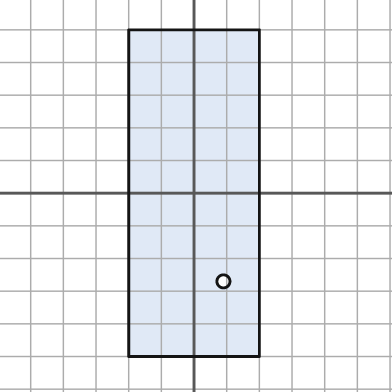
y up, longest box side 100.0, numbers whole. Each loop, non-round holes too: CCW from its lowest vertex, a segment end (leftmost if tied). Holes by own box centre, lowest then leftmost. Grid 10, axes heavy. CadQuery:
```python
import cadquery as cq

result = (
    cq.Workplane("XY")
    .moveTo(-20.0, -50.0)
    .lineTo(20.0, -50.0)
    .lineTo(20.0, 50.0)
    .lineTo(-20.0, 50.0)
    .close()
    .moveTo(9.0, -27.0)
    .circle(2.0)
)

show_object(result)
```